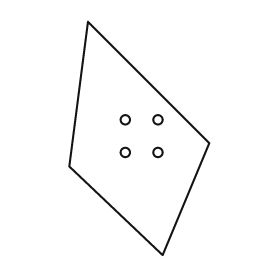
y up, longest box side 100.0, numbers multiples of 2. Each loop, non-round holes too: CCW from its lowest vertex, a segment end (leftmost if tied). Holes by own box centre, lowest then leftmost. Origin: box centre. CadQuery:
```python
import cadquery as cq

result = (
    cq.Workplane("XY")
    .moveTo(10.0, -50.0)
    .lineTo(30.0, -2.0)
    .lineTo(-22.0, 50.0)
    .lineTo(-30.0, -12.0)
    .close()
    .moveTo(-6.0, -6.0)
    .circle(2.0)
    .moveTo(8.0, -6.0)
    .circle(2.0)
    .moveTo(-6.0, 8.0)
    .circle(2.0)
    .moveTo(8.0, 8.0)
    .circle(2.0)
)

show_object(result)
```